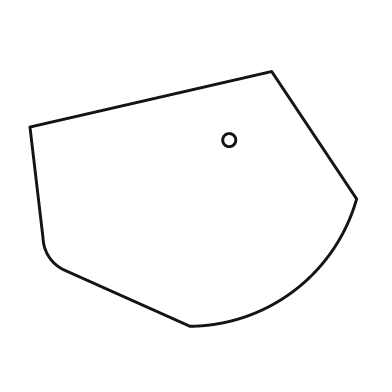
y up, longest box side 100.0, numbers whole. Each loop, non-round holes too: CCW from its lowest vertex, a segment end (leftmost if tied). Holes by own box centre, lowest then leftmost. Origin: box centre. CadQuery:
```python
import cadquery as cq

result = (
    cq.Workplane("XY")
    .moveTo(-1.0, -39.0)
    .threePointArc((31.0, -28.0), (50.0, 0.0))
    .lineTo(24.0, 39.0)
    .lineTo(-50.0, 22.0)
    .lineTo(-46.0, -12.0)
    .threePointArc((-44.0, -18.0), (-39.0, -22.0))
    .close()
    .moveTo(11.0, 18.0)
    .circle(2.0)
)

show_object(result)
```